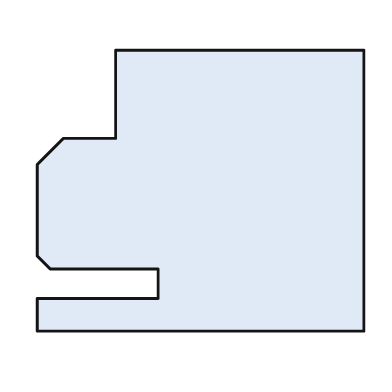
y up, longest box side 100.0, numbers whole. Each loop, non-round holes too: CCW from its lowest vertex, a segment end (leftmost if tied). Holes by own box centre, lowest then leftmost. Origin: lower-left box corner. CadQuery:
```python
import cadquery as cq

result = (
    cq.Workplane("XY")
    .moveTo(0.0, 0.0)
    .lineTo(100.0, 0.0)
    .lineTo(100.0, 86.0)
    .lineTo(24.0, 86.0)
    .lineTo(24.0, 59.0)
    .lineTo(8.0, 59.0)
    .lineTo(0.0, 51.0)
    .lineTo(0.0, 23.0)
    .lineTo(4.0, 19.0)
    .lineTo(37.0, 19.0)
    .lineTo(37.0, 10.0)
    .lineTo(0.0, 10.0)
    .close()
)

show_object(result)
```